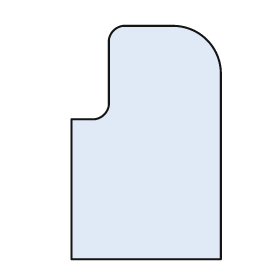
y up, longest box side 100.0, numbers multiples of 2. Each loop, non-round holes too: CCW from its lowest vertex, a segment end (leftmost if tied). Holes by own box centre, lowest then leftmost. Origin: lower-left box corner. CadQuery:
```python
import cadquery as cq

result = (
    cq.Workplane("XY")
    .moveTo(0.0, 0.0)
    .lineTo(64.0, 0.0)
    .lineTo(64.0, 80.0)
    .threePointArc((58.0, 94.0), (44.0, 100.0))
    .lineTo(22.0, 100.0)
    .threePointArc((18.0, 98.0), (16.0, 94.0))
    .lineTo(16.0, 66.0)
    .threePointArc((14.0, 62.0), (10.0, 60.0))
    .lineTo(0.0, 60.0)
    .close()
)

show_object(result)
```